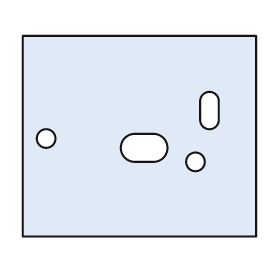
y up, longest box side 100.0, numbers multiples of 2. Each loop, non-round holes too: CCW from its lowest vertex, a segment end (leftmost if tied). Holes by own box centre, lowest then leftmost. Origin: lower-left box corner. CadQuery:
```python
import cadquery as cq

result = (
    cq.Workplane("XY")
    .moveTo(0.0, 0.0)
    .lineTo(100.0, 0.0)
    .lineTo(100.0, 86.0)
    .lineTo(0.0, 86.0)
    .close()
    .moveTo(74.0, 32.0)
    .circle(4.0)
    .moveTo(48.0, 32.0)
    .lineTo(56.0, 32.0)
    .threePointArc((62.0, 38.0), (56.0, 44.0))
    .lineTo(48.0, 44.0)
    .threePointArc((42.0, 38.0), (48.0, 32.0))
    .close()
    .moveTo(10.0, 42.0)
    .circle(4.0)
    .moveTo(76.0, 50.0)
    .threePointArc((80.0, 46.0), (84.0, 50.0))
    .lineTo(84.0, 58.0)
    .threePointArc((80.0, 62.0), (76.0, 58.0))
    .close()
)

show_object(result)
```